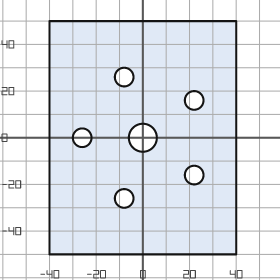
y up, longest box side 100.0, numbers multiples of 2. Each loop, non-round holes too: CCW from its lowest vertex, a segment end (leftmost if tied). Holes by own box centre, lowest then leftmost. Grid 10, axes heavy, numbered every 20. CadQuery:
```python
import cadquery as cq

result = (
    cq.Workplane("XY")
    .moveTo(-40.0, -50.0)
    .lineTo(40.0, -50.0)
    .lineTo(40.0, 50.0)
    .lineTo(-40.0, 50.0)
    .close()
    .moveTo(-8.0, -26.0)
    .circle(4.0)
    .moveTo(22.0, -16.0)
    .circle(4.0)
    .moveTo(-26.0, 0.0)
    .circle(4.0)
    .moveTo(0.0, 0.0)
    .circle(6.0)
    .moveTo(22.0, 16.0)
    .circle(4.0)
    .moveTo(-8.0, 26.0)
    .circle(4.0)
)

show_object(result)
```